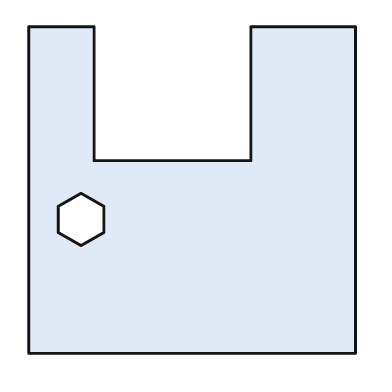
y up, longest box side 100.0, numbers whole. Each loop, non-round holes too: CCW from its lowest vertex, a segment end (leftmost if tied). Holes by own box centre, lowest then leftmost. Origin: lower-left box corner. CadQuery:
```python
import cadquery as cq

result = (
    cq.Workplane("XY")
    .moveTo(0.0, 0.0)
    .lineTo(100.0, 0.0)
    .lineTo(100.0, 100.0)
    .lineTo(68.0, 100.0)
    .lineTo(68.0, 59.0)
    .lineTo(20.0, 59.0)
    .lineTo(20.0, 100.0)
    .lineTo(0.0, 100.0)
    .close()
    .moveTo(16.0, 33.0)
    .lineTo(23.0, 37.0)
    .lineTo(23.0, 45.0)
    .lineTo(16.0, 49.0)
    .lineTo(9.0, 45.0)
    .lineTo(9.0, 37.0)
    .close()
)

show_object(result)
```